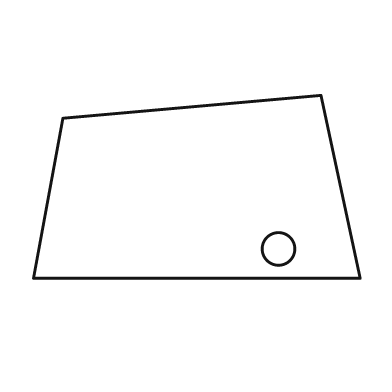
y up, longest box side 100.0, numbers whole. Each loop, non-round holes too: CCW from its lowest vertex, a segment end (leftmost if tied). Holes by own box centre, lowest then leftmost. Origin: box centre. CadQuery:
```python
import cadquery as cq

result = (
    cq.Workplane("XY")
    .moveTo(-50.0, -28.0)
    .lineTo(50.0, -28.0)
    .lineTo(38.0, 28.0)
    .lineTo(-41.0, 21.0)
    .close()
    .moveTo(25.0, -19.0)
    .circle(5.0)
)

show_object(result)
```